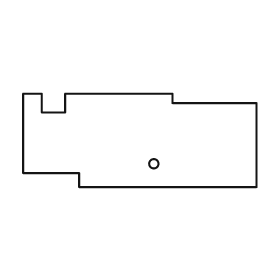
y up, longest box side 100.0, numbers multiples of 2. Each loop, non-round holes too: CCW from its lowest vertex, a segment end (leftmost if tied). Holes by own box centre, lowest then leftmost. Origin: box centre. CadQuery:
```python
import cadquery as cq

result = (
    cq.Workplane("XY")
    .moveTo(-26.0, -20.0)
    .lineTo(50.0, -20.0)
    .lineTo(50.0, 16.0)
    .lineTo(14.0, 16.0)
    .lineTo(14.0, 20.0)
    .lineTo(-32.0, 20.0)
    .lineTo(-32.0, 12.0)
    .lineTo(-42.0, 12.0)
    .lineTo(-42.0, 20.0)
    .lineTo(-50.0, 20.0)
    .lineTo(-50.0, -14.0)
    .lineTo(-26.0, -14.0)
    .close()
    .moveTo(6.0, -10.0)
    .circle(2.0)
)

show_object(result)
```